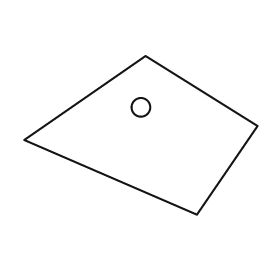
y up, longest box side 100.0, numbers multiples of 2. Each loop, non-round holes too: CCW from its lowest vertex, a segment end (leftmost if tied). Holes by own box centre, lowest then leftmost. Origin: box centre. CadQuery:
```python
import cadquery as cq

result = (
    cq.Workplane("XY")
    .moveTo(24.0, -34.0)
    .lineTo(50.0, 4.0)
    .lineTo(2.0, 34.0)
    .lineTo(-50.0, -2.0)
    .close()
    .moveTo(0.0, 12.0)
    .circle(4.0)
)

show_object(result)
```